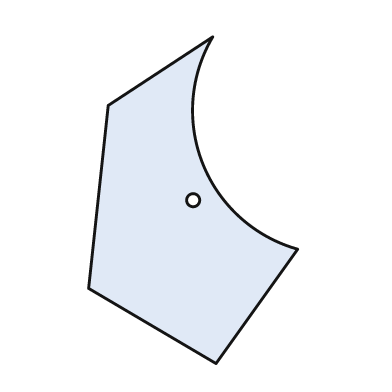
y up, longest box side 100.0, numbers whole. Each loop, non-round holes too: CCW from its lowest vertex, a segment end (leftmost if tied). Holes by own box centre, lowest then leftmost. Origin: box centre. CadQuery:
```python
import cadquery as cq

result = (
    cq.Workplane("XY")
    .moveTo(7.0, -50.0)
    .lineTo(32.0, -15.0)
    .threePointArc((3.0, 11.0), (6.0, 50.0))
    .lineTo(-26.0, 29.0)
    .lineTo(-32.0, -27.0)
    .close()
    .moveTo(0.0, 0.0)
    .circle(2.0)
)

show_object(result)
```